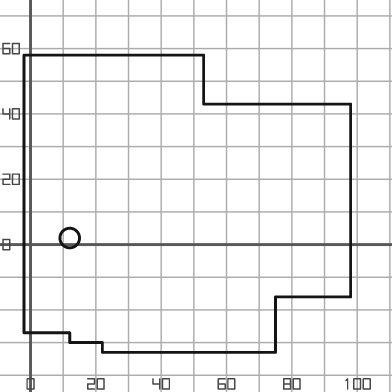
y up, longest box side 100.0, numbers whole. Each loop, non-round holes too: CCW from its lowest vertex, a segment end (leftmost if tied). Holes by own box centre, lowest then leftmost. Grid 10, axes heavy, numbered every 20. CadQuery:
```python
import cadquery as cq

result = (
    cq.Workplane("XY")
    .moveTo(22.0, -33.0)
    .lineTo(75.0, -33.0)
    .lineTo(75.0, -16.0)
    .lineTo(98.0, -16.0)
    .lineTo(98.0, 43.0)
    .lineTo(53.0, 43.0)
    .lineTo(53.0, 58.0)
    .lineTo(-2.0, 58.0)
    .lineTo(-2.0, -27.0)
    .lineTo(12.0, -27.0)
    .lineTo(12.0, -30.0)
    .lineTo(22.0, -30.0)
    .close()
    .moveTo(12.0, 2.0)
    .circle(3.0)
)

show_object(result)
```